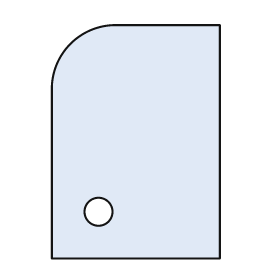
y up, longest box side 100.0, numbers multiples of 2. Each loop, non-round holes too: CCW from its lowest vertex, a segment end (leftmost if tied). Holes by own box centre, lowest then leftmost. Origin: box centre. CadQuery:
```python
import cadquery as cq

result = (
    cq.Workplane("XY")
    .moveTo(-36.0, -50.0)
    .lineTo(36.0, -50.0)
    .lineTo(36.0, 50.0)
    .lineTo(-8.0, 50.0)
    .threePointArc((-28.0, 42.0), (-36.0, 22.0))
    .close()
    .moveTo(-16.0, -30.0)
    .circle(6.0)
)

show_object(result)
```